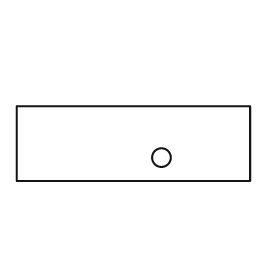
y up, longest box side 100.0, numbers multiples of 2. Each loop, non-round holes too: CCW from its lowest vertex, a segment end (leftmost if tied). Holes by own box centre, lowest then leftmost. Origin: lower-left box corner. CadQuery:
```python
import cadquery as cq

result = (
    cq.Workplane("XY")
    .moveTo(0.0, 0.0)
    .lineTo(100.0, 0.0)
    .lineTo(100.0, 32.0)
    .lineTo(0.0, 32.0)
    .close()
    .moveTo(62.0, 10.0)
    .circle(4.0)
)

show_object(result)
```